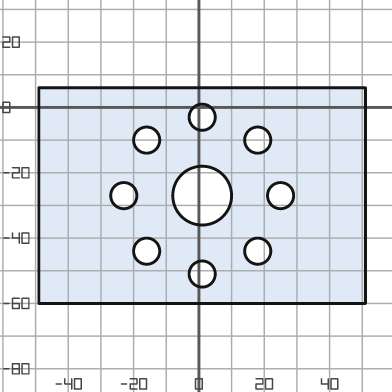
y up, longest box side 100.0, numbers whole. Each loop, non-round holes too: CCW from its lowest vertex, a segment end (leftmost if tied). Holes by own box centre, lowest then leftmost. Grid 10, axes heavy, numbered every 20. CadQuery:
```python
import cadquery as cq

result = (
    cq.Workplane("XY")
    .moveTo(-49.0, -60.0)
    .lineTo(51.0, -60.0)
    .lineTo(51.0, 6.0)
    .lineTo(-49.0, 6.0)
    .close()
    .moveTo(1.0, -51.0)
    .circle(4.0)
    .moveTo(-16.0, -44.0)
    .circle(4.0)
    .moveTo(18.0, -44.0)
    .circle(4.0)
    .moveTo(-23.0, -27.0)
    .circle(4.0)
    .moveTo(1.0, -27.0)
    .circle(9.0)
    .moveTo(25.0, -27.0)
    .circle(4.0)
    .moveTo(-16.0, -10.0)
    .circle(4.0)
    .moveTo(18.0, -10.0)
    .circle(4.0)
    .moveTo(1.0, -3.0)
    .circle(4.0)
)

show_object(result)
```